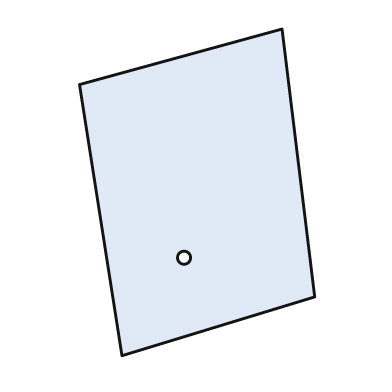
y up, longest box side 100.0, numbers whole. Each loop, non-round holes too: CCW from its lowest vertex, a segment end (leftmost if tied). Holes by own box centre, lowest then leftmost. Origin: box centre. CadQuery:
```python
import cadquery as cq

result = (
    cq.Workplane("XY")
    .moveTo(-23.0, -50.0)
    .lineTo(36.0, -32.0)
    .lineTo(26.0, 50.0)
    .lineTo(-36.0, 33.0)
    .close()
    .moveTo(-4.0, -20.0)
    .circle(2.0)
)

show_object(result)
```